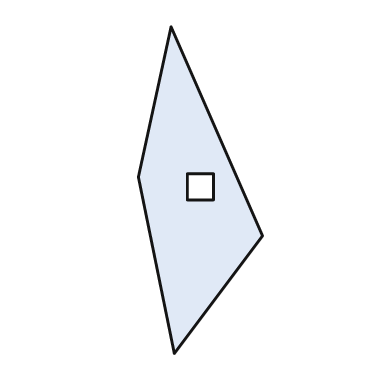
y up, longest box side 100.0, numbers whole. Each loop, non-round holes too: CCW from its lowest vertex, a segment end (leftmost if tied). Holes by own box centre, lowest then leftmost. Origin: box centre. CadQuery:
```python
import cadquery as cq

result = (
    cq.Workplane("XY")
    .moveTo(-8.0, -50.0)
    .lineTo(19.0, -14.0)
    .lineTo(-9.0, 50.0)
    .lineTo(-19.0, 4.0)
    .close()
    .moveTo(-4.0, -3.0)
    .lineTo(4.0, -3.0)
    .lineTo(4.0, 5.0)
    .lineTo(-4.0, 5.0)
    .close()
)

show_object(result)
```